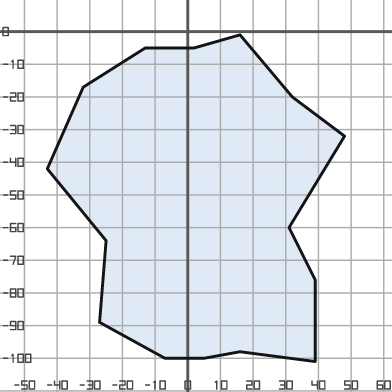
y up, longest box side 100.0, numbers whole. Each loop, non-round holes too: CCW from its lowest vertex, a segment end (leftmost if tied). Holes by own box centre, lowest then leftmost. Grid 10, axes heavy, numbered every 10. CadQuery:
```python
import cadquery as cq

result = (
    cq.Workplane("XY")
    .moveTo(39.0, -101.0)
    .lineTo(39.0, -76.0)
    .lineTo(31.0, -60.0)
    .lineTo(48.0, -32.0)
    .lineTo(32.0, -20.0)
    .lineTo(16.0, -1.0)
    .lineTo(2.0, -5.0)
    .lineTo(-13.0, -5.0)
    .lineTo(-32.0, -17.0)
    .lineTo(-43.0, -42.0)
    .lineTo(-25.0, -64.0)
    .lineTo(-27.0, -89.0)
    .lineTo(-7.0, -100.0)
    .lineTo(5.0, -100.0)
    .lineTo(16.0, -98.0)
    .close()
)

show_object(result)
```